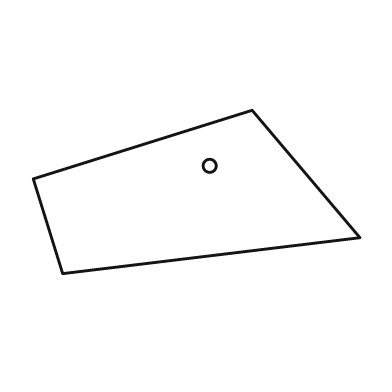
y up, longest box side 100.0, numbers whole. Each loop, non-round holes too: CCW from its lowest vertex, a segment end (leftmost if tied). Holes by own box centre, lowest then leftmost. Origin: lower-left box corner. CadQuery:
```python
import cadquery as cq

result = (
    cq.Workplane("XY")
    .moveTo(9.0, 0.0)
    .lineTo(100.0, 11.0)
    .lineTo(67.0, 50.0)
    .lineTo(0.0, 29.0)
    .close()
    .moveTo(54.0, 33.0)
    .circle(2.0)
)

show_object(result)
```